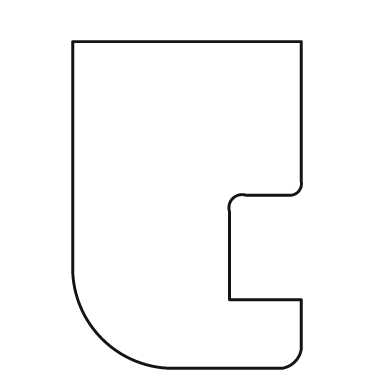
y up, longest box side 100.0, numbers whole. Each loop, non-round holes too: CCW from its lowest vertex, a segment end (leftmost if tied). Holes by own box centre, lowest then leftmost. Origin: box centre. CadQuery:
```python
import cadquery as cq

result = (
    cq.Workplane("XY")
    .moveTo(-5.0, -50.0)
    .lineTo(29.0, -50.0)
    .threePointArc((33.0, -48.0), (35.0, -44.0))
    .lineTo(35.0, -29.0)
    .lineTo(13.0, -29.0)
    .lineTo(13.0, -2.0)
    .threePointArc((14.0, 2.0), (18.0, 3.0))
    .lineTo(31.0, 3.0)
    .threePointArc((34.0, 4.0), (35.0, 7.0))
    .lineTo(35.0, 50.0)
    .lineTo(-35.0, 50.0)
    .lineTo(-35.0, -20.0)
    .threePointArc((-26.0, -41.0), (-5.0, -50.0))
    .close()
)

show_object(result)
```